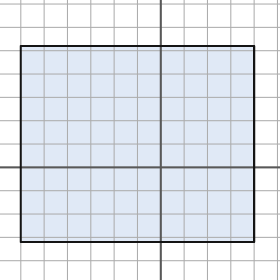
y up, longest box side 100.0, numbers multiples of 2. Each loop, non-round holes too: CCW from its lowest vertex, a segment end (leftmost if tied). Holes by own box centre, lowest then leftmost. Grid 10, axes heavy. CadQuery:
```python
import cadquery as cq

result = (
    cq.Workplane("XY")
    .moveTo(-60.0, -32.0)
    .lineTo(40.0, -32.0)
    .lineTo(40.0, 52.0)
    .lineTo(-60.0, 52.0)
    .close()
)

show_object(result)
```